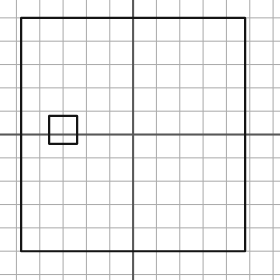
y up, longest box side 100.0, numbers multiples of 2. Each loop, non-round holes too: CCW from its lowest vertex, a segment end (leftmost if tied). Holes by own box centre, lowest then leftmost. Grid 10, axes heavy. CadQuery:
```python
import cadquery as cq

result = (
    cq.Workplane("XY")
    .moveTo(-48.0, -50.0)
    .lineTo(48.0, -50.0)
    .lineTo(48.0, 50.0)
    .lineTo(-48.0, 50.0)
    .close()
    .moveTo(-36.0, -4.0)
    .lineTo(-24.0, -4.0)
    .lineTo(-24.0, 8.0)
    .lineTo(-36.0, 8.0)
    .close()
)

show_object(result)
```